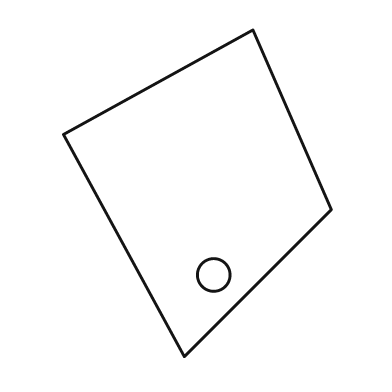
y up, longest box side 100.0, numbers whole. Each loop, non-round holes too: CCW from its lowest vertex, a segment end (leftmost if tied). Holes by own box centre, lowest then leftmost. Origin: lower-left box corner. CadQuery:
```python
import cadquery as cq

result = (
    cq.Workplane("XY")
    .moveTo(37.0, 0.0)
    .lineTo(82.0, 45.0)
    .lineTo(58.0, 100.0)
    .lineTo(0.0, 68.0)
    .close()
    .moveTo(46.0, 25.0)
    .circle(5.0)
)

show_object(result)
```